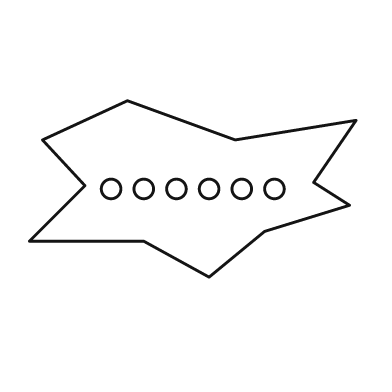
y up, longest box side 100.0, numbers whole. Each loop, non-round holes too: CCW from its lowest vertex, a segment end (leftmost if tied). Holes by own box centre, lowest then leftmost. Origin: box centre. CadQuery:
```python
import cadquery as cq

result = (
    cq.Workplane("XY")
    .moveTo(5.0, -27.0)
    .lineTo(22.0, -13.0)
    .lineTo(48.0, -5.0)
    .lineTo(37.0, 2.0)
    .lineTo(50.0, 21.0)
    .lineTo(13.0, 15.0)
    .lineTo(-20.0, 27.0)
    .lineTo(-46.0, 15.0)
    .lineTo(-33.0, 1.0)
    .lineTo(-50.0, -16.0)
    .lineTo(-15.0, -16.0)
    .close()
    .moveTo(-25.0, 0.0)
    .circle(3.0)
    .moveTo(-15.0, 0.0)
    .circle(3.0)
    .moveTo(-5.0, 0.0)
    .circle(3.0)
    .moveTo(5.0, 0.0)
    .circle(3.0)
    .moveTo(15.0, 0.0)
    .circle(3.0)
    .moveTo(25.0, 0.0)
    .circle(3.0)
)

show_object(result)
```